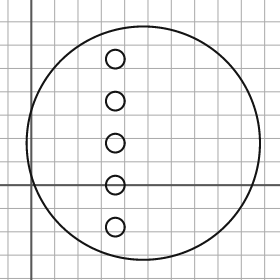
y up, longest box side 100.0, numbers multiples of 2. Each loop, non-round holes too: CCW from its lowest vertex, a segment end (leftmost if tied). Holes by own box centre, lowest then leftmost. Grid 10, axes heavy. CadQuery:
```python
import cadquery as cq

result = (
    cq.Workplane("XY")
    .moveTo(48.0, 18.0)
    .circle(50.0)
    .moveTo(36.0, -18.0)
    .circle(4.0)
    .moveTo(36.0, 0.0)
    .circle(4.0)
    .moveTo(36.0, 18.0)
    .circle(4.0)
    .moveTo(36.0, 36.0)
    .circle(4.0)
    .moveTo(36.0, 54.0)
    .circle(4.0)
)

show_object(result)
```